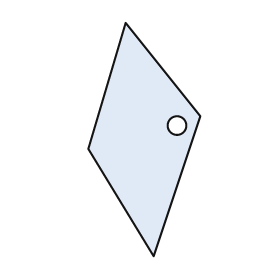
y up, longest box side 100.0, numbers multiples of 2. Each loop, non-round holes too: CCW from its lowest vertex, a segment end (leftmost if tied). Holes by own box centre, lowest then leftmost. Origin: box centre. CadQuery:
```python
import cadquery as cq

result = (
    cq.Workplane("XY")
    .moveTo(4.0, -50.0)
    .lineTo(24.0, 10.0)
    .lineTo(-8.0, 50.0)
    .lineTo(-24.0, -4.0)
    .close()
    .moveTo(14.0, 6.0)
    .circle(4.0)
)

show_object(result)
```